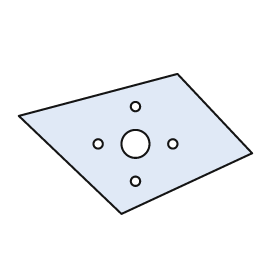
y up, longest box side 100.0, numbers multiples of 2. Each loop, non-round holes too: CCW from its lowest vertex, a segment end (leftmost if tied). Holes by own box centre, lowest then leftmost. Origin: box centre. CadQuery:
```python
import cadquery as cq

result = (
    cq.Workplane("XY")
    .moveTo(-6.0, -30.0)
    .lineTo(50.0, -4.0)
    .lineTo(18.0, 30.0)
    .lineTo(-50.0, 12.0)
    .close()
    .moveTo(0.0, -16.0)
    .circle(2.0)
    .moveTo(-16.0, 0.0)
    .circle(2.0)
    .moveTo(0.0, 0.0)
    .circle(6.0)
    .moveTo(16.0, 0.0)
    .circle(2.0)
    .moveTo(0.0, 16.0)
    .circle(2.0)
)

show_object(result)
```